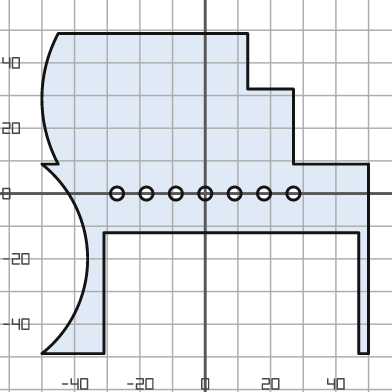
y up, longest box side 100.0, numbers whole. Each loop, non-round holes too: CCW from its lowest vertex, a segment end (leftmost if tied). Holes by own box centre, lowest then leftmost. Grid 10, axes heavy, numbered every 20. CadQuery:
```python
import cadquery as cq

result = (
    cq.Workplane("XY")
    .moveTo(-50.0, -49.0)
    .lineTo(-31.0, -49.0)
    .lineTo(-31.0, -12.0)
    .lineTo(47.0, -12.0)
    .lineTo(47.0, -49.0)
    .lineTo(50.0, -49.0)
    .lineTo(50.0, 9.0)
    .lineTo(27.0, 9.0)
    .lineTo(27.0, 32.0)
    .lineTo(13.0, 32.0)
    .lineTo(13.0, 49.0)
    .lineTo(-45.0, 49.0)
    .threePointArc((-50.0, 29.0), (-45.0, 9.0))
    .lineTo(-50.0, 9.0)
    .threePointArc((-36.0, -20.0), (-50.0, -49.0))
    .close()
    .moveTo(-27.0, 0.0)
    .circle(2.0)
    .moveTo(-18.0, 0.0)
    .circle(2.0)
    .moveTo(-9.0, 0.0)
    .circle(2.0)
    .moveTo(0.0, 0.0)
    .circle(2.0)
    .moveTo(9.0, 0.0)
    .circle(2.0)
    .moveTo(18.0, 0.0)
    .circle(2.0)
    .moveTo(27.0, 0.0)
    .circle(2.0)
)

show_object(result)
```